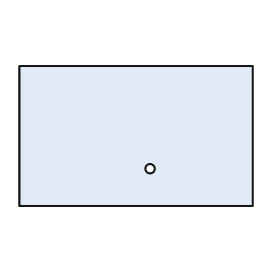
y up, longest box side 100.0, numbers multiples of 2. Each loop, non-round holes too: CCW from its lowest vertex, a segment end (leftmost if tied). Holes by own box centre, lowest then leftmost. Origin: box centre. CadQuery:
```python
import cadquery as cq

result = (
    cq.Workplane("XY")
    .moveTo(-50.0, -30.0)
    .lineTo(50.0, -30.0)
    .lineTo(50.0, 30.0)
    .lineTo(-50.0, 30.0)
    .close()
    .moveTo(6.0, -14.0)
    .circle(2.0)
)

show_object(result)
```